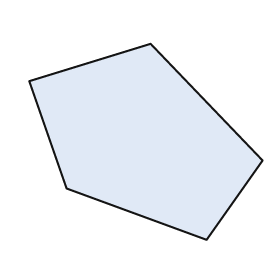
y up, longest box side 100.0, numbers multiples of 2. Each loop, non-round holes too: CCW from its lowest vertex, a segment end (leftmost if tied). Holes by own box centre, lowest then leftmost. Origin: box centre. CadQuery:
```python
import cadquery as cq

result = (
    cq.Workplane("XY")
    .moveTo(26.0, -42.0)
    .lineTo(50.0, -8.0)
    .lineTo(2.0, 42.0)
    .lineTo(-50.0, 26.0)
    .lineTo(-34.0, -20.0)
    .close()
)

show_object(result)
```